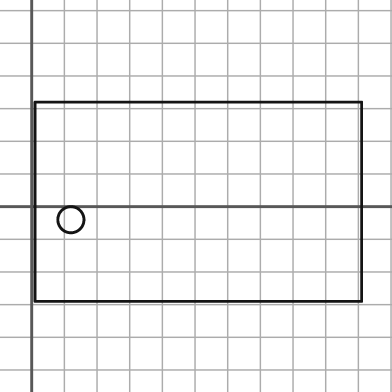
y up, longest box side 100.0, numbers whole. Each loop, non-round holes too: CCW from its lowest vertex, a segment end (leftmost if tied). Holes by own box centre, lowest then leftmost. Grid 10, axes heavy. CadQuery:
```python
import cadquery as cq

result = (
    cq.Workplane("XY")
    .moveTo(1.0, -29.0)
    .lineTo(101.0, -29.0)
    .lineTo(101.0, 32.0)
    .lineTo(1.0, 32.0)
    .close()
    .moveTo(12.0, -4.0)
    .circle(4.0)
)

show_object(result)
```